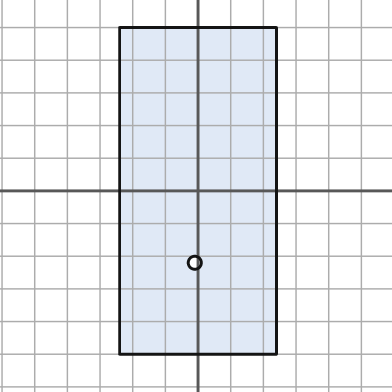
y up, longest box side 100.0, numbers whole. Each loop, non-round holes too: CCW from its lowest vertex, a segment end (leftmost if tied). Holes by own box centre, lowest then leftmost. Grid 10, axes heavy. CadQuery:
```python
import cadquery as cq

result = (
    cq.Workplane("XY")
    .moveTo(-24.0, -50.0)
    .lineTo(24.0, -50.0)
    .lineTo(24.0, 50.0)
    .lineTo(-24.0, 50.0)
    .close()
    .moveTo(-1.0, -22.0)
    .circle(2.0)
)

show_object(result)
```